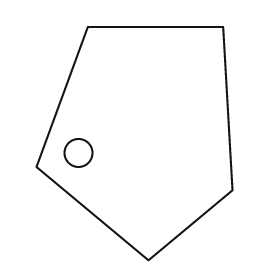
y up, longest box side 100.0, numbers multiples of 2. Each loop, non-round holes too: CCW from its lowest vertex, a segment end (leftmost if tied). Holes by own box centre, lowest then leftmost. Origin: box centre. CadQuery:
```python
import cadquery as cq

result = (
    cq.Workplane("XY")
    .moveTo(6.0, -50.0)
    .lineTo(42.0, -20.0)
    .lineTo(38.0, 50.0)
    .lineTo(-20.0, 50.0)
    .lineTo(-42.0, -10.0)
    .close()
    .moveTo(-24.0, -4.0)
    .circle(6.0)
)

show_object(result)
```